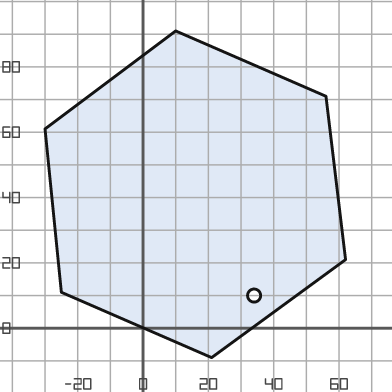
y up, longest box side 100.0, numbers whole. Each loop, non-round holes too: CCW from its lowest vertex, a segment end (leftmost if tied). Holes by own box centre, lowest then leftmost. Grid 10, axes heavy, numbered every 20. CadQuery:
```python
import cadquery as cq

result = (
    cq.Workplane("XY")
    .moveTo(21.0, -9.0)
    .lineTo(62.0, 21.0)
    .lineTo(56.0, 71.0)
    .lineTo(10.0, 91.0)
    .lineTo(-30.0, 61.0)
    .lineTo(-25.0, 11.0)
    .close()
    .moveTo(34.0, 10.0)
    .circle(2.0)
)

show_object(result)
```